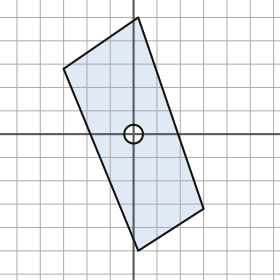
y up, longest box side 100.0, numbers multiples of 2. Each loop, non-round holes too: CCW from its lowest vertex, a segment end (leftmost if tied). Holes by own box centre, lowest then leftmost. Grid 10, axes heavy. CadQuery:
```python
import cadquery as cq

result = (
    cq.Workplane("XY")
    .moveTo(2.0, -50.0)
    .lineTo(30.0, -32.0)
    .lineTo(2.0, 50.0)
    .lineTo(-30.0, 28.0)
    .close()
    .moveTo(0.0, 0.0)
    .circle(4.0)
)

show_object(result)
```